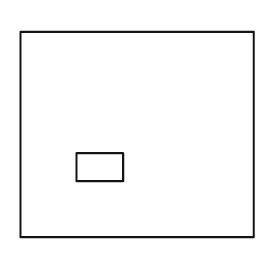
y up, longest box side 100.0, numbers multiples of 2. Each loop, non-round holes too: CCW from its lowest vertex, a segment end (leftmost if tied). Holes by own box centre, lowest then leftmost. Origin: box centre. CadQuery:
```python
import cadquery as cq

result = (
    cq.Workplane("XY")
    .moveTo(-50.0, -44.0)
    .lineTo(50.0, -44.0)
    .lineTo(50.0, 44.0)
    .lineTo(-50.0, 44.0)
    .close()
    .moveTo(-26.0, -20.0)
    .lineTo(-6.0, -20.0)
    .lineTo(-6.0, -8.0)
    .lineTo(-26.0, -8.0)
    .close()
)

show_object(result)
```